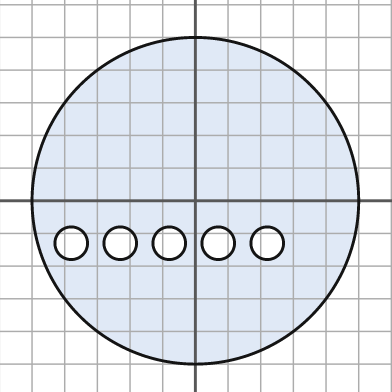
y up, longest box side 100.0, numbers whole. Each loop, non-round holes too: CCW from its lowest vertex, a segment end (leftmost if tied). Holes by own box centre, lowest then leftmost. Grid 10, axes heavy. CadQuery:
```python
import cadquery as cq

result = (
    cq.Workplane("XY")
    .moveTo(0.0, 0.0)
    .circle(50.0)
    .moveTo(-38.0, -13.0)
    .circle(5.0)
    .moveTo(-23.0, -13.0)
    .circle(5.0)
    .moveTo(-8.0, -13.0)
    .circle(5.0)
    .moveTo(7.0, -13.0)
    .circle(5.0)
    .moveTo(22.0, -13.0)
    .circle(5.0)
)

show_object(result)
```